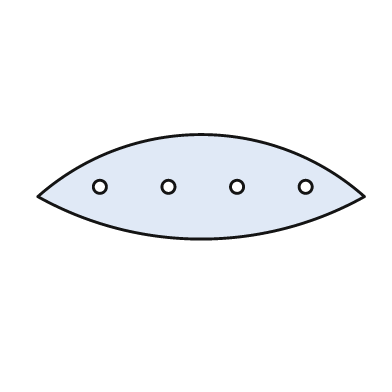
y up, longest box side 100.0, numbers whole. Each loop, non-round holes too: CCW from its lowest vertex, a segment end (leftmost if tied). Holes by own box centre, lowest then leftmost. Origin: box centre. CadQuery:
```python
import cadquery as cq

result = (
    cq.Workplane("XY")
    .moveTo(-50.0, -3.0)
    .threePointArc((0.0, -16.0), (50.0, -3.0))
    .threePointArc((0.0, 16.0), (-50.0, -3.0))
    .close()
    .moveTo(-31.0, 0.0)
    .circle(2.0)
    .moveTo(-10.0, 0.0)
    .circle(2.0)
    .moveTo(11.0, 0.0)
    .circle(2.0)
    .moveTo(32.0, 0.0)
    .circle(2.0)
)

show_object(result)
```